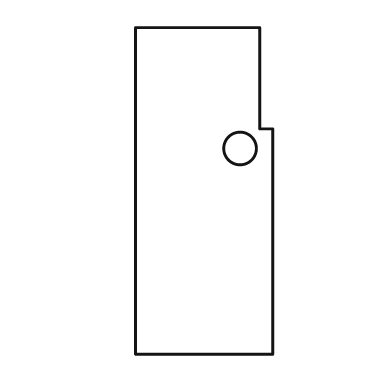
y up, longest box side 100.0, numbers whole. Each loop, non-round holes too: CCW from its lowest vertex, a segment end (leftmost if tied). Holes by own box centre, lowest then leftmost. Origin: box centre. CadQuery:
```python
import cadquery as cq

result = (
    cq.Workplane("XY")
    .moveTo(-21.0, -50.0)
    .lineTo(21.0, -50.0)
    .lineTo(21.0, 19.0)
    .lineTo(17.0, 19.0)
    .lineTo(17.0, 50.0)
    .lineTo(-21.0, 50.0)
    .close()
    .moveTo(11.0, 13.0)
    .circle(5.0)
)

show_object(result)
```